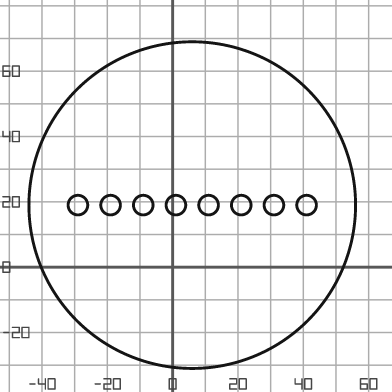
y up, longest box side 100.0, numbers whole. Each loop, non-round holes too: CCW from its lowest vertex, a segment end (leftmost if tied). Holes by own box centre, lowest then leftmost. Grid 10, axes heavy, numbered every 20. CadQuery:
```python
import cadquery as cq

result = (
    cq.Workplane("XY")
    .moveTo(6.0, 19.0)
    .circle(50.0)
    .moveTo(-29.0, 19.0)
    .circle(3.0)
    .moveTo(-19.0, 19.0)
    .circle(3.0)
    .moveTo(-9.0, 19.0)
    .circle(3.0)
    .moveTo(1.0, 19.0)
    .circle(3.0)
    .moveTo(11.0, 19.0)
    .circle(3.0)
    .moveTo(21.0, 19.0)
    .circle(3.0)
    .moveTo(31.0, 19.0)
    .circle(3.0)
    .moveTo(41.0, 19.0)
    .circle(3.0)
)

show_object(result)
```